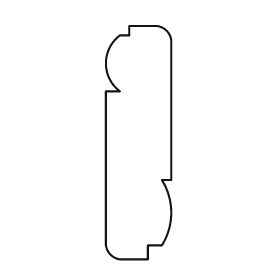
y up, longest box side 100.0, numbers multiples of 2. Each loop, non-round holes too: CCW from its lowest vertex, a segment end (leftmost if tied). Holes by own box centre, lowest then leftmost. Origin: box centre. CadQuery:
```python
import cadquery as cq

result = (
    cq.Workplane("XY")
    .moveTo(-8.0, -50.0)
    .lineTo(4.0, -50.0)
    .lineTo(4.0, -44.0)
    .lineTo(10.0, -44.0)
    .threePointArc((14.0, -30.0), (10.0, -16.0))
    .lineTo(14.0, -16.0)
    .lineTo(14.0, 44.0)
    .threePointArc((12.0, 48.0), (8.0, 50.0))
    .lineTo(-4.0, 50.0)
    .lineTo(-4.0, 46.0)
    .lineTo(-8.0, 46.0)
    .threePointArc((-14.0, 34.0), (-8.0, 22.0))
    .lineTo(-14.0, 22.0)
    .lineTo(-14.0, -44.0)
    .threePointArc((-12.0, -48.0), (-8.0, -50.0))
    .close()
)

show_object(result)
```